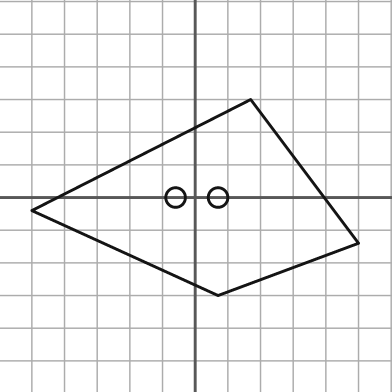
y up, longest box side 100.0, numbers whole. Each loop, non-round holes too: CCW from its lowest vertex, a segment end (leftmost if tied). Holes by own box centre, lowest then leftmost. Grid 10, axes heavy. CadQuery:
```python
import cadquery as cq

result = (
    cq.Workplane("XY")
    .moveTo(7.0, -30.0)
    .lineTo(50.0, -14.0)
    .lineTo(17.0, 30.0)
    .lineTo(-50.0, -4.0)
    .close()
    .moveTo(-6.0, 0.0)
    .circle(3.0)
    .moveTo(7.0, 0.0)
    .circle(3.0)
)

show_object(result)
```